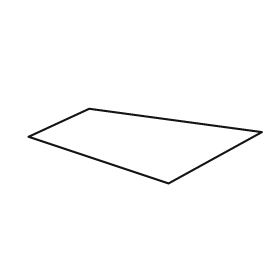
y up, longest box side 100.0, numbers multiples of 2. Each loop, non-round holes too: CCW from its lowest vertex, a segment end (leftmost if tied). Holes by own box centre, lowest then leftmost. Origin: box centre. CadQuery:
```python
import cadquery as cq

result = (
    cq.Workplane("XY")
    .moveTo(10.0, -16.0)
    .lineTo(50.0, 6.0)
    .lineTo(-24.0, 16.0)
    .lineTo(-50.0, 4.0)
    .close()
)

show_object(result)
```